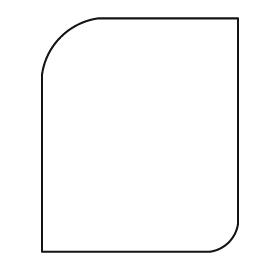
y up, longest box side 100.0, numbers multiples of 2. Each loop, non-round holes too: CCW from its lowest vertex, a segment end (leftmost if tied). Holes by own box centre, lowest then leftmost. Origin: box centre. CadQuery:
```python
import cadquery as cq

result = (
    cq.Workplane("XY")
    .moveTo(-42.0, -50.0)
    .lineTo(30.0, -50.0)
    .threePointArc((38.0, -46.0), (42.0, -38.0))
    .lineTo(42.0, 50.0)
    .lineTo(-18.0, 50.0)
    .threePointArc((-34.0, 42.0), (-42.0, 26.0))
    .close()
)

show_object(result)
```